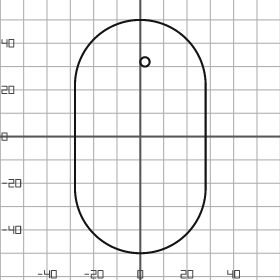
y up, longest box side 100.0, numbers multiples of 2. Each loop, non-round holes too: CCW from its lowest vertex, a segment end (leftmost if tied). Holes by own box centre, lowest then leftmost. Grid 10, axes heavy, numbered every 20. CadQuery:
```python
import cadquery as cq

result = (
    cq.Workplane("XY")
    .moveTo(-28.0, -22.0)
    .threePointArc((0.0, -50.0), (28.0, -22.0))
    .lineTo(28.0, 22.0)
    .threePointArc((0.0, 50.0), (-28.0, 22.0))
    .close()
    .moveTo(2.0, 32.0)
    .circle(2.0)
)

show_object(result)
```